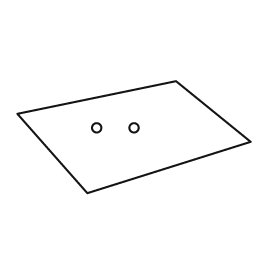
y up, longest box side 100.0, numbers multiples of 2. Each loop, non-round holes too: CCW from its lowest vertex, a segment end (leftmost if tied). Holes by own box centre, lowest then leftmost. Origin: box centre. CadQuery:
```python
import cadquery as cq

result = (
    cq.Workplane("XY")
    .moveTo(-20.0, -24.0)
    .lineTo(50.0, -2.0)
    .lineTo(18.0, 24.0)
    .lineTo(-50.0, 10.0)
    .close()
    .moveTo(-16.0, 4.0)
    .circle(2.0)
    .moveTo(0.0, 4.0)
    .circle(2.0)
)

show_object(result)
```